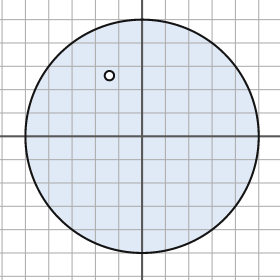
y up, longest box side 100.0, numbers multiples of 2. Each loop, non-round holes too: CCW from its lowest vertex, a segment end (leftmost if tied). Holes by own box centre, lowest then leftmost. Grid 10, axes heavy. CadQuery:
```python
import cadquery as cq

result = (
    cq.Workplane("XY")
    .moveTo(0.0, 0.0)
    .circle(50.0)
    .moveTo(-14.0, 26.0)
    .circle(2.0)
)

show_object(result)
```